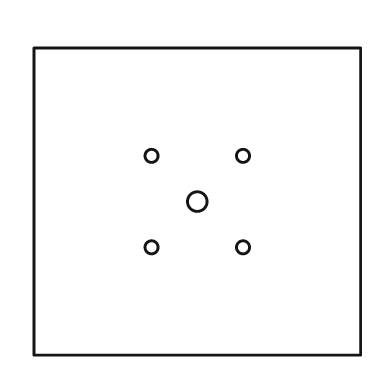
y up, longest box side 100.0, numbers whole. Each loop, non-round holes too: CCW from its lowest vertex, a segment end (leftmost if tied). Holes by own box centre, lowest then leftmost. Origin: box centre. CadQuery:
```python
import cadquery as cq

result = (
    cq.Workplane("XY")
    .moveTo(-50.0, -47.0)
    .lineTo(50.0, -47.0)
    .lineTo(50.0, 47.0)
    .lineTo(-50.0, 47.0)
    .close()
    .moveTo(-14.0, -14.0)
    .circle(2.0)
    .moveTo(14.0, -14.0)
    .circle(2.0)
    .moveTo(0.0, 0.0)
    .circle(3.0)
    .moveTo(-14.0, 14.0)
    .circle(2.0)
    .moveTo(14.0, 14.0)
    .circle(2.0)
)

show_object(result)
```